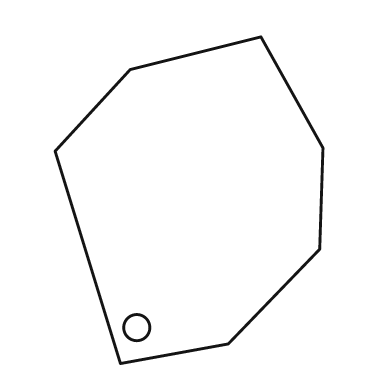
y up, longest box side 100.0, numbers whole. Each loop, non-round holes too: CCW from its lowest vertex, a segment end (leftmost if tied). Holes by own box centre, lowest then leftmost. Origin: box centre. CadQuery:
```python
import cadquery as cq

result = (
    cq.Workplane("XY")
    .moveTo(-21.0, -50.0)
    .lineTo(12.0, -44.0)
    .lineTo(40.0, -15.0)
    .lineTo(41.0, 16.0)
    .lineTo(22.0, 50.0)
    .lineTo(-18.0, 40.0)
    .lineTo(-41.0, 15.0)
    .close()
    .moveTo(-16.0, -39.0)
    .circle(4.0)
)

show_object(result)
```